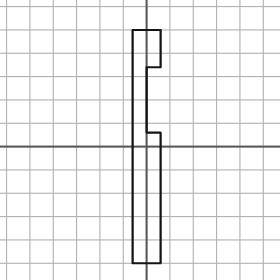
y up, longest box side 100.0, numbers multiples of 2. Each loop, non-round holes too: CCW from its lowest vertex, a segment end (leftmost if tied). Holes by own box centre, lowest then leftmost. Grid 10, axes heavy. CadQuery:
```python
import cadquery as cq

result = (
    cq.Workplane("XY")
    .moveTo(-6.0, -50.0)
    .lineTo(6.0, -50.0)
    .lineTo(6.0, 6.0)
    .lineTo(0.0, 6.0)
    .lineTo(0.0, 34.0)
    .lineTo(6.0, 34.0)
    .lineTo(6.0, 50.0)
    .lineTo(-6.0, 50.0)
    .close()
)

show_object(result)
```